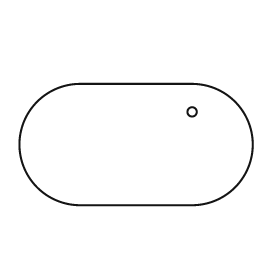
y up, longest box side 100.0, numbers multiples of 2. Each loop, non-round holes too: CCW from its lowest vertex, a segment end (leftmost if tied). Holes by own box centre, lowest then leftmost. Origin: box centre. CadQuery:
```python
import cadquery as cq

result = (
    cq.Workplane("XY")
    .moveTo(-24.0, -26.0)
    .lineTo(24.0, -26.0)
    .threePointArc((50.0, 0.0), (24.0, 26.0))
    .lineTo(-24.0, 26.0)
    .threePointArc((-50.0, 0.0), (-24.0, -26.0))
    .close()
    .moveTo(24.0, 14.0)
    .circle(2.0)
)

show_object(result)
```